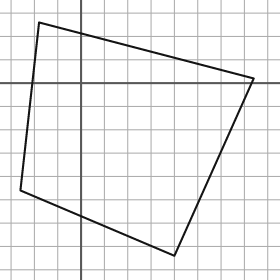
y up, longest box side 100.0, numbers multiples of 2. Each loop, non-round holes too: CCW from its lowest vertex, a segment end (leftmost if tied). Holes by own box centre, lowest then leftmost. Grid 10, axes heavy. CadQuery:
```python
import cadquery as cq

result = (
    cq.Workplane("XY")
    .moveTo(40.0, -74.0)
    .lineTo(74.0, 2.0)
    .lineTo(-18.0, 26.0)
    .lineTo(-26.0, -46.0)
    .close()
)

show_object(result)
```